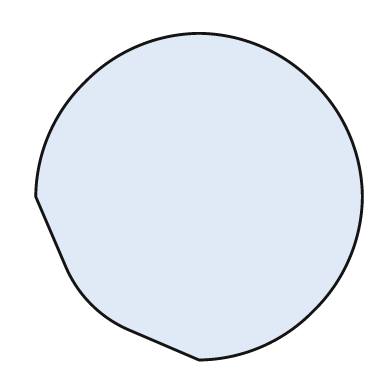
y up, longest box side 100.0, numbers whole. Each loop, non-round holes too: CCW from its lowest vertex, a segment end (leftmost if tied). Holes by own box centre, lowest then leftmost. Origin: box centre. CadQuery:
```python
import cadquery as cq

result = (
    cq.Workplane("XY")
    .moveTo(0.0, -50.0)
    .threePointArc((19.0, -46.0), (35.0, -35.0))
    .threePointArc((46.0, -19.0), (50.0, 0.0))
    .threePointArc((46.0, 19.0), (35.0, 35.0))
    .threePointArc((19.0, 46.0), (0.0, 50.0))
    .threePointArc((-19.0, 46.0), (-35.0, 35.0))
    .threePointArc((-46.0, 19.0), (-50.0, 0.0))
    .lineTo(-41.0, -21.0)
    .threePointArc((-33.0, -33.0), (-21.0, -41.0))
    .close()
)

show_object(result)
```